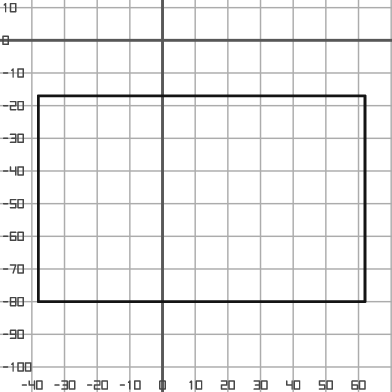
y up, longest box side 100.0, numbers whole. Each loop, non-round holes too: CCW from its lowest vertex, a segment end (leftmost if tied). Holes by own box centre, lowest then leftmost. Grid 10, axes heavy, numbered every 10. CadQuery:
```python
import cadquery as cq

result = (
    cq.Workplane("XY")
    .moveTo(-38.0, -80.0)
    .lineTo(62.0, -80.0)
    .lineTo(62.0, -17.0)
    .lineTo(-38.0, -17.0)
    .close()
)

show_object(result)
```